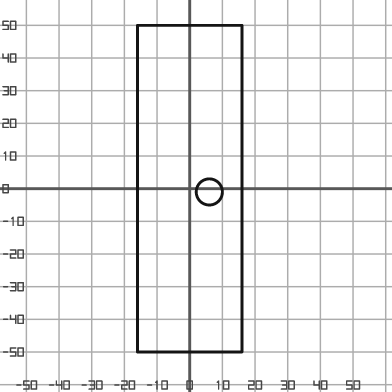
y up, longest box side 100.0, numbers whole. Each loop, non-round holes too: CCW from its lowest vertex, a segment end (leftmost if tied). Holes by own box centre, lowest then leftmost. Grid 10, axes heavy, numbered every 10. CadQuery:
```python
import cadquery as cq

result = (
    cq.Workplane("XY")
    .moveTo(-16.0, -50.0)
    .lineTo(16.0, -50.0)
    .lineTo(16.0, 50.0)
    .lineTo(-16.0, 50.0)
    .close()
    .moveTo(6.0, -1.0)
    .circle(4.0)
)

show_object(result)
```